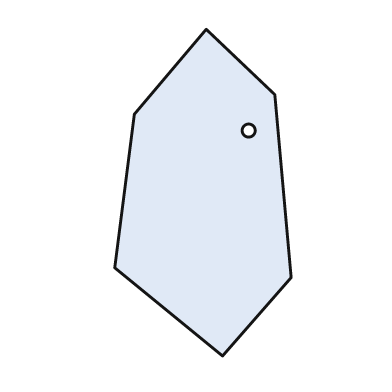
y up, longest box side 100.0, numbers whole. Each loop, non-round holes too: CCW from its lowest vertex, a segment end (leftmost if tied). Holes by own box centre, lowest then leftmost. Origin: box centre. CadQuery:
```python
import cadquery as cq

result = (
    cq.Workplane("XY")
    .moveTo(6.0, -50.0)
    .lineTo(27.0, -26.0)
    .lineTo(22.0, 30.0)
    .lineTo(1.0, 50.0)
    .lineTo(-21.0, 24.0)
    .lineTo(-27.0, -23.0)
    .close()
    .moveTo(14.0, 19.0)
    .circle(2.0)
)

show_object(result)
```